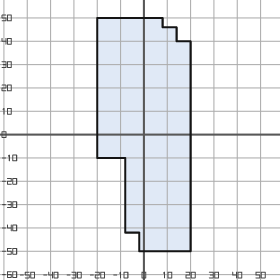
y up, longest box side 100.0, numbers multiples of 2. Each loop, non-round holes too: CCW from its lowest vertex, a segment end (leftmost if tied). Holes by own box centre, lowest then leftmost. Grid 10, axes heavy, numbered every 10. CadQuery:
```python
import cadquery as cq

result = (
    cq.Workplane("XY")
    .moveTo(-2.0, -50.0)
    .lineTo(20.0, -50.0)
    .lineTo(20.0, 40.0)
    .lineTo(14.0, 40.0)
    .lineTo(14.0, 46.0)
    .lineTo(8.0, 46.0)
    .lineTo(8.0, 50.0)
    .lineTo(-20.0, 50.0)
    .lineTo(-20.0, -10.0)
    .lineTo(-8.0, -10.0)
    .lineTo(-8.0, -42.0)
    .lineTo(-2.0, -42.0)
    .close()
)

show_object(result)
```